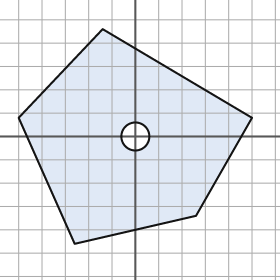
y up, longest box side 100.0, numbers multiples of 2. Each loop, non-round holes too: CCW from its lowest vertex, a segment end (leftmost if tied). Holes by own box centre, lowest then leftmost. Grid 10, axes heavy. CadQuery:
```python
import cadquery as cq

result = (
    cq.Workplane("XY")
    .moveTo(-26.0, -46.0)
    .lineTo(26.0, -34.0)
    .lineTo(50.0, 8.0)
    .lineTo(-14.0, 46.0)
    .lineTo(-50.0, 8.0)
    .close()
    .moveTo(0.0, 0.0)
    .circle(6.0)
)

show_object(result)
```